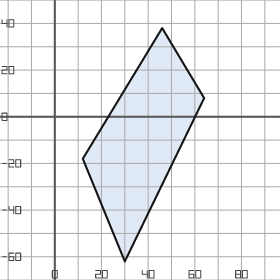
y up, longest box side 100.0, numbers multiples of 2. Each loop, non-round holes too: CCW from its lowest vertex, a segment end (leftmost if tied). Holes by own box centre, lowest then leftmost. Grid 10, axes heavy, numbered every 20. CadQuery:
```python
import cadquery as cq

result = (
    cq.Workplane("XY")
    .moveTo(30.0, -62.0)
    .lineTo(64.0, 8.0)
    .lineTo(46.0, 38.0)
    .lineTo(12.0, -18.0)
    .close()
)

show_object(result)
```